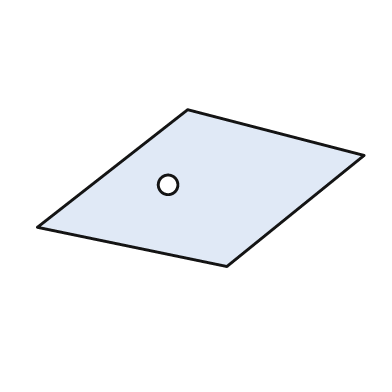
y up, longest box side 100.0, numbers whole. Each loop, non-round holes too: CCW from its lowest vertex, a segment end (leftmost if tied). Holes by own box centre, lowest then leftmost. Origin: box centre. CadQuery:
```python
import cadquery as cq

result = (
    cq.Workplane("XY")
    .moveTo(8.0, -24.0)
    .lineTo(50.0, 10.0)
    .lineTo(-4.0, 24.0)
    .lineTo(-50.0, -12.0)
    .close()
    .moveTo(-10.0, 1.0)
    .circle(3.0)
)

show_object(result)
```